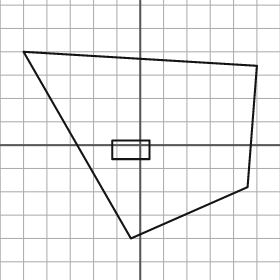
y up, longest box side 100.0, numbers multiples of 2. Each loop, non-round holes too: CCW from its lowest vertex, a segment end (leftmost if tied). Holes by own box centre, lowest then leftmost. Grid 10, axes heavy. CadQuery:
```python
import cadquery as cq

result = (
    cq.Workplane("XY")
    .moveTo(-4.0, -40.0)
    .lineTo(46.0, -18.0)
    .lineTo(50.0, 34.0)
    .lineTo(-50.0, 40.0)
    .close()
    .moveTo(-12.0, -6.0)
    .lineTo(4.0, -6.0)
    .lineTo(4.0, 2.0)
    .lineTo(-12.0, 2.0)
    .close()
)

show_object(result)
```